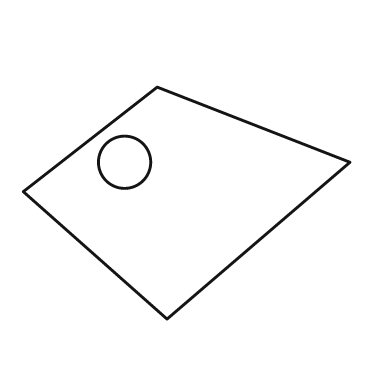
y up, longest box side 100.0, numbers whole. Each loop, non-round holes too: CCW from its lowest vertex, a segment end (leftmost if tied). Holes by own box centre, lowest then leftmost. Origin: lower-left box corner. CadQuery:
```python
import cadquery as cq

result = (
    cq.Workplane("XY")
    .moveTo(44.0, 0.0)
    .lineTo(100.0, 48.0)
    .lineTo(41.0, 71.0)
    .lineTo(0.0, 39.0)
    .close()
    .moveTo(31.0, 48.0)
    .circle(8.0)
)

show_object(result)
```